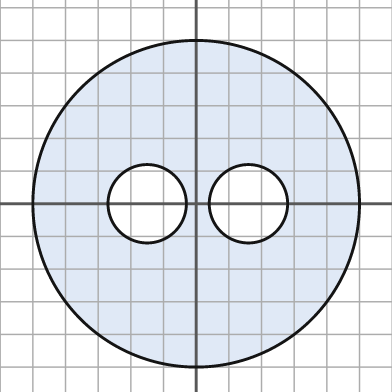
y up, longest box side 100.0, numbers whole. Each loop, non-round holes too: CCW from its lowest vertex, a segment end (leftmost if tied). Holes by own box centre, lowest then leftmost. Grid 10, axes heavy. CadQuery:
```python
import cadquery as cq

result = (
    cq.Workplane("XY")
    .moveTo(0.0, 0.0)
    .circle(50.0)
    .moveTo(-15.0, 0.0)
    .circle(12.0)
    .moveTo(16.0, 0.0)
    .circle(12.0)
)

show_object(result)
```